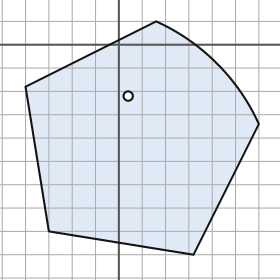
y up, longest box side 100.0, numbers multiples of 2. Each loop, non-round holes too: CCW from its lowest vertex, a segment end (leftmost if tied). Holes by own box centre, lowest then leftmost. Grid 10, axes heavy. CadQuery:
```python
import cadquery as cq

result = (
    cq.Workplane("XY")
    .moveTo(32.0, -90.0)
    .lineTo(60.0, -34.0)
    .threePointArc((42.0, -8.0), (16.0, 10.0))
    .lineTo(-40.0, -18.0)
    .lineTo(-30.0, -80.0)
    .close()
    .moveTo(4.0, -22.0)
    .circle(2.0)
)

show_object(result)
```